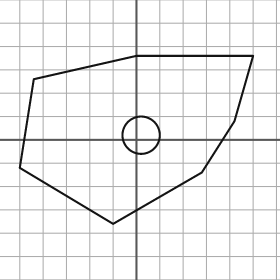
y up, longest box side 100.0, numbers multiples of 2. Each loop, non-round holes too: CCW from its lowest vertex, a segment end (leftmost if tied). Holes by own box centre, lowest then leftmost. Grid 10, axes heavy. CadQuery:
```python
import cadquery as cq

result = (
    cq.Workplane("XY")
    .moveTo(-10.0, -36.0)
    .lineTo(28.0, -14.0)
    .lineTo(42.0, 8.0)
    .lineTo(50.0, 36.0)
    .lineTo(0.0, 36.0)
    .lineTo(-44.0, 26.0)
    .lineTo(-50.0, -12.0)
    .close()
    .moveTo(2.0, 2.0)
    .circle(8.0)
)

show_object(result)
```